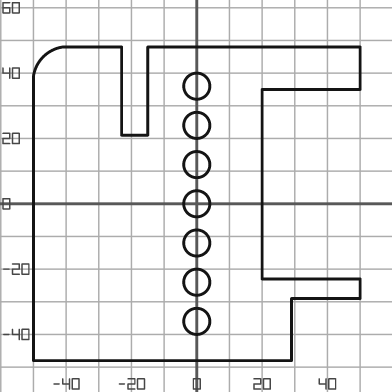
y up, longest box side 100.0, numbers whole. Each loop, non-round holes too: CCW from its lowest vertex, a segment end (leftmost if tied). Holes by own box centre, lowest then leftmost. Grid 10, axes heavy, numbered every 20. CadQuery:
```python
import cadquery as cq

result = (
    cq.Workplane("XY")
    .moveTo(-50.0, -48.0)
    .lineTo(29.0, -48.0)
    .lineTo(29.0, -29.0)
    .lineTo(50.0, -29.0)
    .lineTo(50.0, -23.0)
    .lineTo(20.0, -23.0)
    .lineTo(20.0, 35.0)
    .lineTo(50.0, 35.0)
    .lineTo(50.0, 48.0)
    .lineTo(-15.0, 48.0)
    .lineTo(-15.0, 21.0)
    .lineTo(-23.0, 21.0)
    .lineTo(-23.0, 48.0)
    .lineTo(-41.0, 48.0)
    .threePointArc((-47.0, 45.0), (-50.0, 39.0))
    .close()
    .moveTo(0.0, -36.0)
    .circle(4.0)
    .moveTo(0.0, -24.0)
    .circle(4.0)
    .moveTo(0.0, -12.0)
    .circle(4.0)
    .moveTo(0.0, 0.0)
    .circle(4.0)
    .moveTo(0.0, 12.0)
    .circle(4.0)
    .moveTo(0.0, 24.0)
    .circle(4.0)
    .moveTo(0.0, 36.0)
    .circle(4.0)
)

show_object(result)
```